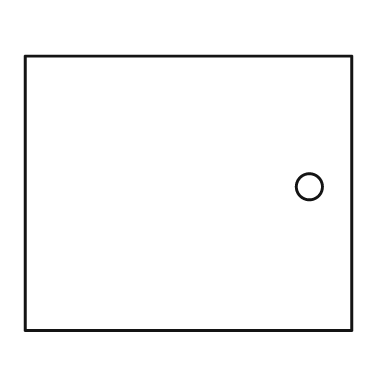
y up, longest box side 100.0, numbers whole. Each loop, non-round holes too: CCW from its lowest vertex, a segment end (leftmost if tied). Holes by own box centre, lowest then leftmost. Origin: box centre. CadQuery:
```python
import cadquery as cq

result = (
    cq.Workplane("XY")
    .moveTo(-50.0, -42.0)
    .lineTo(50.0, -42.0)
    .lineTo(50.0, 42.0)
    .lineTo(-50.0, 42.0)
    .close()
    .moveTo(37.0, 2.0)
    .circle(4.0)
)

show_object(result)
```